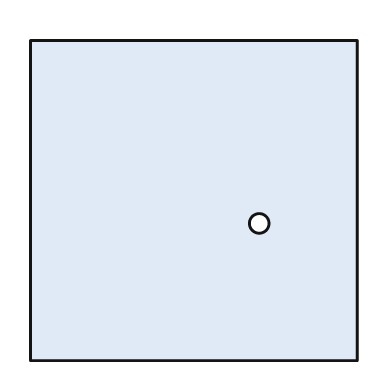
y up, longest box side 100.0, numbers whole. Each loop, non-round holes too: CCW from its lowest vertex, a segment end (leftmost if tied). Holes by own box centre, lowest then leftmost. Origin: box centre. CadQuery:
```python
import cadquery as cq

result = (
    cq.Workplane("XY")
    .moveTo(-50.0, -49.0)
    .lineTo(50.0, -49.0)
    .lineTo(50.0, 49.0)
    .lineTo(-50.0, 49.0)
    .close()
    .moveTo(20.0, -7.0)
    .circle(3.0)
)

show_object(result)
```